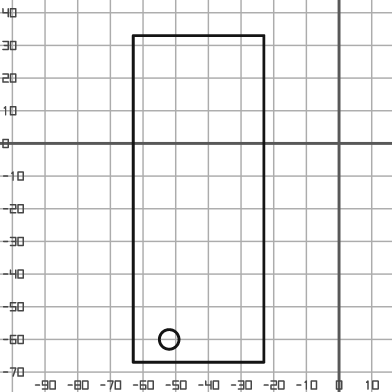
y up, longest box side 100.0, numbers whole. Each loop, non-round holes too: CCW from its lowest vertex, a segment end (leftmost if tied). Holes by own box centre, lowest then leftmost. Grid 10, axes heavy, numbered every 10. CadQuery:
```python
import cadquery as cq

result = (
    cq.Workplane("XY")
    .moveTo(-63.0, -67.0)
    .lineTo(-23.0, -67.0)
    .lineTo(-23.0, 33.0)
    .lineTo(-63.0, 33.0)
    .close()
    .moveTo(-52.0, -60.0)
    .circle(3.0)
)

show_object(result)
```